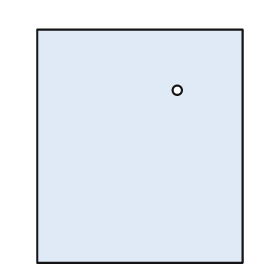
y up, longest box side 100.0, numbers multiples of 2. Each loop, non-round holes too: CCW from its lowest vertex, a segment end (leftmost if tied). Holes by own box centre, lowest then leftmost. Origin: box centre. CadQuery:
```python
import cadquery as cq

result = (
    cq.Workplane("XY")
    .moveTo(-44.0, -50.0)
    .lineTo(44.0, -50.0)
    .lineTo(44.0, 50.0)
    .lineTo(-44.0, 50.0)
    .close()
    .moveTo(16.0, 24.0)
    .circle(2.0)
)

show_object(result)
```